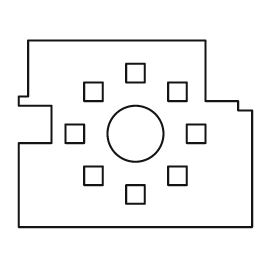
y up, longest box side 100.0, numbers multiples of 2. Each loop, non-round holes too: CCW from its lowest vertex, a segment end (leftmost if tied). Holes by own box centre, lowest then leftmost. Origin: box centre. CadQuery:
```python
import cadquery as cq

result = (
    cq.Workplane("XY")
    .moveTo(-50.0, -40.0)
    .lineTo(50.0, -40.0)
    .lineTo(50.0, 10.0)
    .lineTo(44.0, 10.0)
    .lineTo(44.0, 14.0)
    .lineTo(30.0, 14.0)
    .lineTo(30.0, 40.0)
    .lineTo(-46.0, 40.0)
    .lineTo(-46.0, 16.0)
    .lineTo(-50.0, 16.0)
    .lineTo(-50.0, 12.0)
    .lineTo(-36.0, 12.0)
    .lineTo(-36.0, -4.0)
    .lineTo(-50.0, -4.0)
    .close()
    .moveTo(-4.0, -30.0)
    .lineTo(4.0, -30.0)
    .lineTo(4.0, -22.0)
    .lineTo(-4.0, -22.0)
    .close()
    .moveTo(-22.0, -22.0)
    .lineTo(-14.0, -22.0)
    .lineTo(-14.0, -14.0)
    .lineTo(-22.0, -14.0)
    .close()
    .moveTo(14.0, -22.0)
    .lineTo(22.0, -22.0)
    .lineTo(22.0, -14.0)
    .lineTo(14.0, -14.0)
    .close()
    .moveTo(-30.0, -4.0)
    .lineTo(-22.0, -4.0)
    .lineTo(-22.0, 4.0)
    .lineTo(-30.0, 4.0)
    .close()
    .moveTo(0.0, 0.0)
    .circle(12.0)
    .moveTo(22.0, -4.0)
    .lineTo(30.0, -4.0)
    .lineTo(30.0, 4.0)
    .lineTo(22.0, 4.0)
    .close()
    .moveTo(-22.0, 14.0)
    .lineTo(-14.0, 14.0)
    .lineTo(-14.0, 22.0)
    .lineTo(-22.0, 22.0)
    .close()
    .moveTo(14.0, 14.0)
    .lineTo(22.0, 14.0)
    .lineTo(22.0, 22.0)
    .lineTo(14.0, 22.0)
    .close()
    .moveTo(-4.0, 22.0)
    .lineTo(4.0, 22.0)
    .lineTo(4.0, 30.0)
    .lineTo(-4.0, 30.0)
    .close()
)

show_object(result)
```